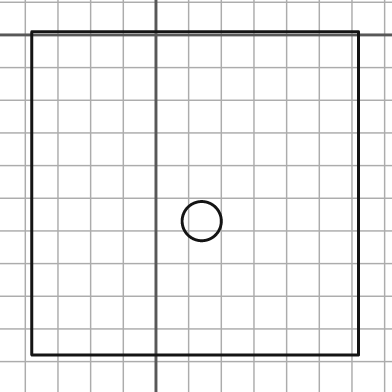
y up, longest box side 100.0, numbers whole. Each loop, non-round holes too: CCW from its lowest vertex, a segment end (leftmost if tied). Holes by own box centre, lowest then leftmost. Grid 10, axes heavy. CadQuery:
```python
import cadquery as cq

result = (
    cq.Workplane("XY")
    .moveTo(-38.0, -98.0)
    .lineTo(62.0, -98.0)
    .lineTo(62.0, 1.0)
    .lineTo(-38.0, 1.0)
    .close()
    .moveTo(14.0, -57.0)
    .circle(6.0)
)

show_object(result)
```